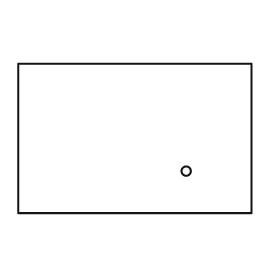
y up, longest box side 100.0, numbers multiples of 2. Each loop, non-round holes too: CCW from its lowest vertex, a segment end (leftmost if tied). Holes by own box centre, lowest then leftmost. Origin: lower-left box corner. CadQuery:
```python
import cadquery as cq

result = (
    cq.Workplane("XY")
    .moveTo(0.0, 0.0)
    .lineTo(100.0, 0.0)
    .lineTo(100.0, 64.0)
    .lineTo(0.0, 64.0)
    .close()
    .moveTo(72.0, 18.0)
    .circle(2.0)
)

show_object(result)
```